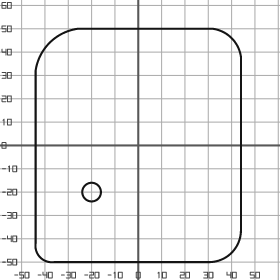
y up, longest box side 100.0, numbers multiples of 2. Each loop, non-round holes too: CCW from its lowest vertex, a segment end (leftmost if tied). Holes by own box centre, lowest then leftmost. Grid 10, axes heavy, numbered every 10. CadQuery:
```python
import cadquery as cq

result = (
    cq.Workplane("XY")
    .moveTo(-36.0, -50.0)
    .lineTo(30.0, -50.0)
    .threePointArc((40.0, -46.0), (44.0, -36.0))
    .lineTo(44.0, 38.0)
    .threePointArc((40.0, 46.0), (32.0, 50.0))
    .lineTo(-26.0, 50.0)
    .threePointArc((-38.0, 44.0), (-44.0, 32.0))
    .lineTo(-44.0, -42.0)
    .threePointArc((-42.0, -48.0), (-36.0, -50.0))
    .close()
    .moveTo(-20.0, -20.0)
    .circle(4.0)
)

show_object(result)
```